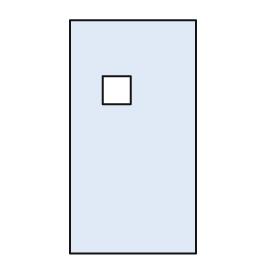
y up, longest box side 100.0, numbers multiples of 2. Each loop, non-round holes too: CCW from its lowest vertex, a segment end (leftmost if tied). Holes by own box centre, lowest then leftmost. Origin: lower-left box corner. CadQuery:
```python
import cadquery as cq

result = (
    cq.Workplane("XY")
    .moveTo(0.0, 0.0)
    .lineTo(54.0, 0.0)
    .lineTo(54.0, 100.0)
    .lineTo(0.0, 100.0)
    .close()
    .moveTo(14.0, 64.0)
    .lineTo(26.0, 64.0)
    .lineTo(26.0, 76.0)
    .lineTo(14.0, 76.0)
    .close()
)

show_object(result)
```